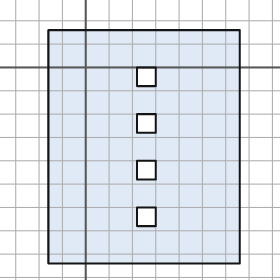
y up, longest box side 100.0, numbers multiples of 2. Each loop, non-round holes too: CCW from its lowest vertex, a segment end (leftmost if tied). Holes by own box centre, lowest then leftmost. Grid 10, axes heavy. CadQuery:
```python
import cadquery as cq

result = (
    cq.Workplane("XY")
    .moveTo(-16.0, -84.0)
    .lineTo(66.0, -84.0)
    .lineTo(66.0, 16.0)
    .lineTo(-16.0, 16.0)
    .close()
    .moveTo(22.0, -68.0)
    .lineTo(30.0, -68.0)
    .lineTo(30.0, -60.0)
    .lineTo(22.0, -60.0)
    .close()
    .moveTo(22.0, -48.0)
    .lineTo(30.0, -48.0)
    .lineTo(30.0, -40.0)
    .lineTo(22.0, -40.0)
    .close()
    .moveTo(22.0, -28.0)
    .lineTo(30.0, -28.0)
    .lineTo(30.0, -20.0)
    .lineTo(22.0, -20.0)
    .close()
    .moveTo(22.0, -8.0)
    .lineTo(30.0, -8.0)
    .lineTo(30.0, 0.0)
    .lineTo(22.0, 0.0)
    .close()
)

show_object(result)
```